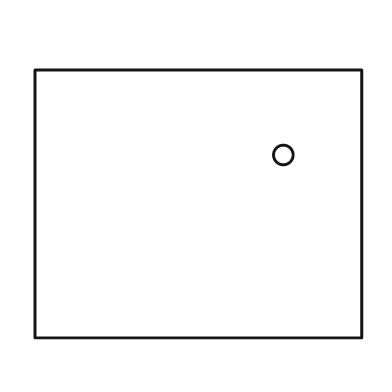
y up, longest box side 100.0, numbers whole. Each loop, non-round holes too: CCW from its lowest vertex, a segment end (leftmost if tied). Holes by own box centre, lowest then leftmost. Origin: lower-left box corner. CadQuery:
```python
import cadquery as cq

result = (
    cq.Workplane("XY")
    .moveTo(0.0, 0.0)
    .lineTo(100.0, 0.0)
    .lineTo(100.0, 82.0)
    .lineTo(0.0, 82.0)
    .close()
    .moveTo(76.0, 56.0)
    .circle(3.0)
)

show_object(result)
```